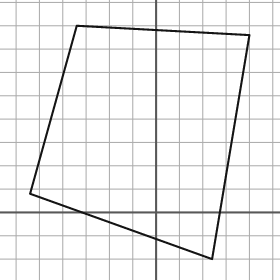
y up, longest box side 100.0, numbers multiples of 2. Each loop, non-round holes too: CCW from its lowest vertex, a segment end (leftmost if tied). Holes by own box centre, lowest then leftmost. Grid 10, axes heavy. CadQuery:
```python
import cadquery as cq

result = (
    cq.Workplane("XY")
    .moveTo(24.0, -20.0)
    .lineTo(40.0, 76.0)
    .lineTo(-34.0, 80.0)
    .lineTo(-54.0, 8.0)
    .close()
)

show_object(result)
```